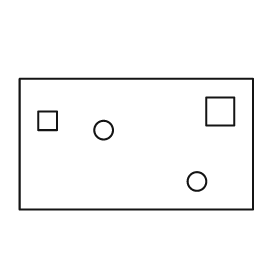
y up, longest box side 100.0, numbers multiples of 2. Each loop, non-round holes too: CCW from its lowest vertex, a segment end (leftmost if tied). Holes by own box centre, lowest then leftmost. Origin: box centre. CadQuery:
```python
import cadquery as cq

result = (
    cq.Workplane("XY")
    .moveTo(-50.0, -28.0)
    .lineTo(50.0, -28.0)
    .lineTo(50.0, 28.0)
    .lineTo(-50.0, 28.0)
    .close()
    .moveTo(26.0, -16.0)
    .circle(4.0)
    .moveTo(-14.0, 6.0)
    .circle(4.0)
    .moveTo(-42.0, 6.0)
    .lineTo(-34.0, 6.0)
    .lineTo(-34.0, 14.0)
    .lineTo(-42.0, 14.0)
    .close()
    .moveTo(30.0, 8.0)
    .lineTo(42.0, 8.0)
    .lineTo(42.0, 20.0)
    .lineTo(30.0, 20.0)
    .close()
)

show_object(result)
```